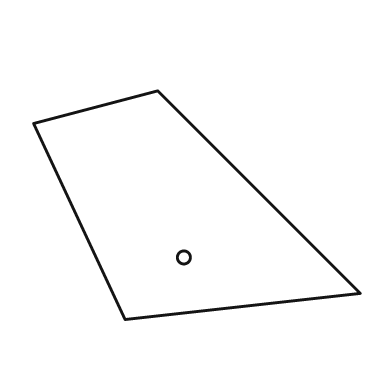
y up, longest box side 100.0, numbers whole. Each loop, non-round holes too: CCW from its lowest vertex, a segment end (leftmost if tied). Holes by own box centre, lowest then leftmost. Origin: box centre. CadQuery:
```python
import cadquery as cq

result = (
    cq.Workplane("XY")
    .moveTo(-22.0, -35.0)
    .lineTo(50.0, -27.0)
    .lineTo(-12.0, 35.0)
    .lineTo(-50.0, 25.0)
    .close()
    .moveTo(-4.0, -16.0)
    .circle(2.0)
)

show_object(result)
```